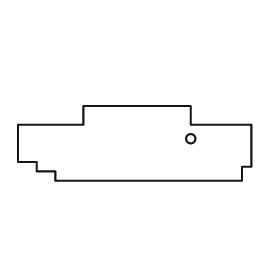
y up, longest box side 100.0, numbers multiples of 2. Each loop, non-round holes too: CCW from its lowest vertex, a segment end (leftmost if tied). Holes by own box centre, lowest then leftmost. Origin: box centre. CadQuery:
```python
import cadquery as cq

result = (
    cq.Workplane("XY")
    .moveTo(-34.0, -16.0)
    .lineTo(46.0, -16.0)
    .lineTo(46.0, -10.0)
    .lineTo(50.0, -10.0)
    .lineTo(50.0, 8.0)
    .lineTo(24.0, 8.0)
    .lineTo(24.0, 16.0)
    .lineTo(-22.0, 16.0)
    .lineTo(-22.0, 8.0)
    .lineTo(-50.0, 8.0)
    .lineTo(-50.0, -8.0)
    .lineTo(-42.0, -8.0)
    .lineTo(-42.0, -12.0)
    .lineTo(-34.0, -12.0)
    .close()
    .moveTo(24.0, 2.0)
    .circle(2.0)
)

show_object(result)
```